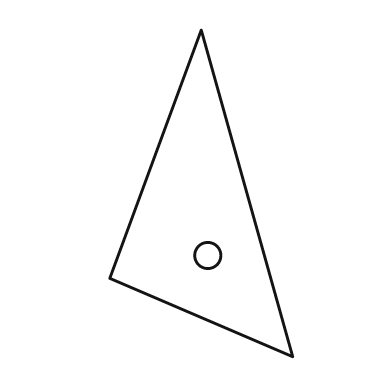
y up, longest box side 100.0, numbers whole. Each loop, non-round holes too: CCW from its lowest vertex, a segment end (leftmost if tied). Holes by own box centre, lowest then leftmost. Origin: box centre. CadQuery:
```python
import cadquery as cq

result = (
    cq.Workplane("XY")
    .moveTo(28.0, -50.0)
    .lineTo(0.0, 50.0)
    .lineTo(-28.0, -26.0)
    .close()
    .moveTo(2.0, -19.0)
    .circle(4.0)
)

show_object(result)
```